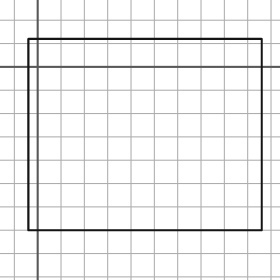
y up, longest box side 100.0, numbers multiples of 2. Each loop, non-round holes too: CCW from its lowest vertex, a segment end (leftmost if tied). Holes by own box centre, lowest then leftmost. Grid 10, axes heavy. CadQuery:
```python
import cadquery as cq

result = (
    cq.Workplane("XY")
    .moveTo(-4.0, -70.0)
    .lineTo(96.0, -70.0)
    .lineTo(96.0, 12.0)
    .lineTo(-4.0, 12.0)
    .close()
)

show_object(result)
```